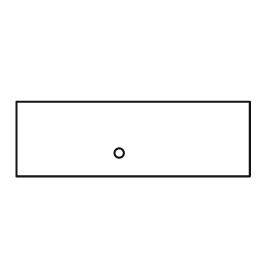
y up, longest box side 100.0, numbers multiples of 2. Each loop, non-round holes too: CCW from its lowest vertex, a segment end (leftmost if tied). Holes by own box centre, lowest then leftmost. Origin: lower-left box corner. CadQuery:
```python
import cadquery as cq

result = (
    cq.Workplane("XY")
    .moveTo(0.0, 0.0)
    .lineTo(100.0, 0.0)
    .lineTo(100.0, 32.0)
    .lineTo(0.0, 32.0)
    .close()
    .moveTo(44.0, 10.0)
    .circle(2.0)
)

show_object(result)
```